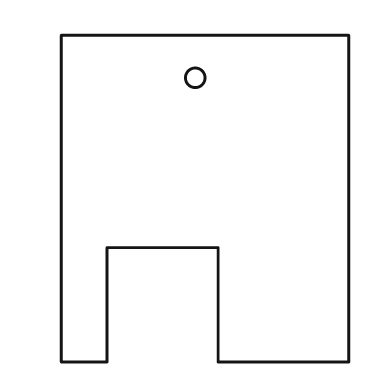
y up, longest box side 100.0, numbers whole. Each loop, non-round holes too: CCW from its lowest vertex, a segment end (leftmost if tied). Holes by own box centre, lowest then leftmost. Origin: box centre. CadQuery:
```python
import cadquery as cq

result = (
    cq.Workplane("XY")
    .moveTo(-44.0, -50.0)
    .lineTo(-30.0, -50.0)
    .lineTo(-30.0, -15.0)
    .lineTo(4.0, -15.0)
    .lineTo(4.0, -50.0)
    .lineTo(44.0, -50.0)
    .lineTo(44.0, 50.0)
    .lineTo(-44.0, 50.0)
    .close()
    .moveTo(-3.0, 37.0)
    .circle(3.0)
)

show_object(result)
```